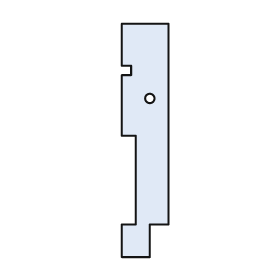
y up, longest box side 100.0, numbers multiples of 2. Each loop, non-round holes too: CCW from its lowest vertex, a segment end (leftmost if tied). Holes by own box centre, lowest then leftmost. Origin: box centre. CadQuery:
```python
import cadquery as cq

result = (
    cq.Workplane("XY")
    .moveTo(-10.0, -50.0)
    .lineTo(2.0, -50.0)
    .lineTo(2.0, -36.0)
    .lineTo(10.0, -36.0)
    .lineTo(10.0, 50.0)
    .lineTo(-10.0, 50.0)
    .lineTo(-10.0, 32.0)
    .lineTo(-6.0, 32.0)
    .lineTo(-6.0, 28.0)
    .lineTo(-10.0, 28.0)
    .lineTo(-10.0, 2.0)
    .lineTo(-4.0, 2.0)
    .lineTo(-4.0, -36.0)
    .lineTo(-10.0, -36.0)
    .close()
    .moveTo(2.0, 18.0)
    .circle(2.0)
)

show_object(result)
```